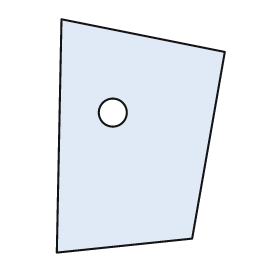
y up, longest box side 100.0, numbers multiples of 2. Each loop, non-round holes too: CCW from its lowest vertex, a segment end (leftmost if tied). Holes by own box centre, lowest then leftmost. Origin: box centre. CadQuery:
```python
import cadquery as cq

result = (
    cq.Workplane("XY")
    .moveTo(-36.0, -50.0)
    .lineTo(22.0, -44.0)
    .lineTo(36.0, 36.0)
    .lineTo(-34.0, 50.0)
    .close()
    .moveTo(-12.0, 10.0)
    .circle(6.0)
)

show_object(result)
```